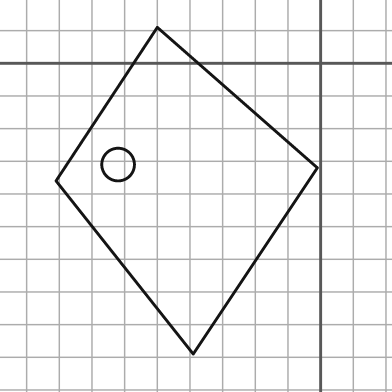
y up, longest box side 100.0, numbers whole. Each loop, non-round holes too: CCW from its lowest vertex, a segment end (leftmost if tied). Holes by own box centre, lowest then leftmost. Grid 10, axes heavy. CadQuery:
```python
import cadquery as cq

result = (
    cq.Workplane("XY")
    .moveTo(-39.0, -89.0)
    .lineTo(-1.0, -32.0)
    .lineTo(-50.0, 11.0)
    .lineTo(-81.0, -36.0)
    .close()
    .moveTo(-62.0, -31.0)
    .circle(5.0)
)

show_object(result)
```